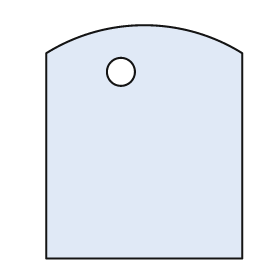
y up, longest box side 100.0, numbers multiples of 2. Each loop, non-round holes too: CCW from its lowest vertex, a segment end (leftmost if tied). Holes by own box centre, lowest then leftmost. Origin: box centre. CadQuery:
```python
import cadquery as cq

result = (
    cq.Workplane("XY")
    .moveTo(-42.0, -50.0)
    .lineTo(42.0, -50.0)
    .lineTo(42.0, 38.0)
    .threePointArc((0.0, 50.0), (-42.0, 38.0))
    .close()
    .moveTo(-10.0, 30.0)
    .circle(6.0)
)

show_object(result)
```